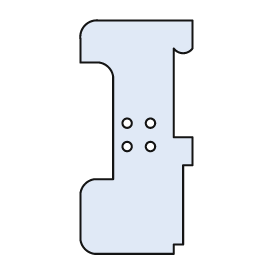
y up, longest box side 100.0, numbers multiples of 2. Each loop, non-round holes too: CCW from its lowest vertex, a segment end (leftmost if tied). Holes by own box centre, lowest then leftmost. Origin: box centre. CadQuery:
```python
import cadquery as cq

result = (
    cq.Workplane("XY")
    .moveTo(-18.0, -50.0)
    .lineTo(16.0, -50.0)
    .lineTo(16.0, -46.0)
    .lineTo(20.0, -46.0)
    .lineTo(20.0, -12.0)
    .lineTo(24.0, -12.0)
    .lineTo(24.0, 0.0)
    .lineTo(16.0, 0.0)
    .lineTo(16.0, 38.0)
    .threePointArc((20.0, 36.0), (24.0, 38.0))
    .lineTo(24.0, 50.0)
    .lineTo(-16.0, 50.0)
    .threePointArc((-22.0, 48.0), (-24.0, 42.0))
    .lineTo(-24.0, 32.0)
    .lineTo(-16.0, 32.0)
    .threePointArc((-12.0, 30.0), (-10.0, 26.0))
    .lineTo(-10.0, -18.0)
    .lineTo(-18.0, -18.0)
    .threePointArc((-22.0, -20.0), (-24.0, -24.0))
    .lineTo(-24.0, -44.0)
    .threePointArc((-22.0, -48.0), (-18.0, -50.0))
    .close()
    .moveTo(-4.0, -4.0)
    .circle(2.0)
    .moveTo(6.0, -4.0)
    .circle(2.0)
    .moveTo(-4.0, 6.0)
    .circle(2.0)
    .moveTo(6.0, 6.0)
    .circle(2.0)
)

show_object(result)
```